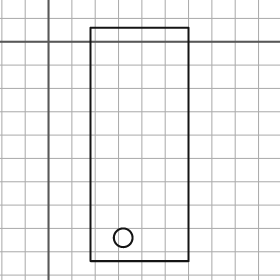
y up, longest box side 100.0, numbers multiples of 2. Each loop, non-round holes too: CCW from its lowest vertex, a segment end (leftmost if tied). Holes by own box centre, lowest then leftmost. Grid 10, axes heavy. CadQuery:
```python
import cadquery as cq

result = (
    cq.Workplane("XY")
    .moveTo(18.0, -94.0)
    .lineTo(60.0, -94.0)
    .lineTo(60.0, 6.0)
    .lineTo(18.0, 6.0)
    .close()
    .moveTo(32.0, -84.0)
    .circle(4.0)
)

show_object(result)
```